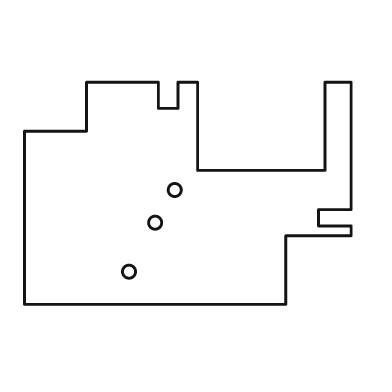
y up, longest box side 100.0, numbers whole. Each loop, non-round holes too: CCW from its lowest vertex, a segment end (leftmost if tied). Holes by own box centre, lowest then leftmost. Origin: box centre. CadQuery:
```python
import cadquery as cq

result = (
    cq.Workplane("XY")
    .moveTo(-50.0, -34.0)
    .lineTo(30.0, -34.0)
    .lineTo(30.0, -13.0)
    .lineTo(50.0, -13.0)
    .lineTo(50.0, -10.0)
    .lineTo(40.0, -10.0)
    .lineTo(40.0, -5.0)
    .lineTo(50.0, -5.0)
    .lineTo(50.0, 34.0)
    .lineTo(42.0, 34.0)
    .lineTo(42.0, 7.0)
    .lineTo(3.0, 7.0)
    .lineTo(3.0, 34.0)
    .lineTo(-3.0, 34.0)
    .lineTo(-3.0, 26.0)
    .lineTo(-9.0, 26.0)
    .lineTo(-9.0, 34.0)
    .lineTo(-31.0, 34.0)
    .lineTo(-31.0, 19.0)
    .lineTo(-50.0, 19.0)
    .close()
    .moveTo(-18.0, -24.0)
    .circle(2.0)
    .moveTo(-10.0, -9.0)
    .circle(2.0)
    .moveTo(-4.0, 1.0)
    .circle(2.0)
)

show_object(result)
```